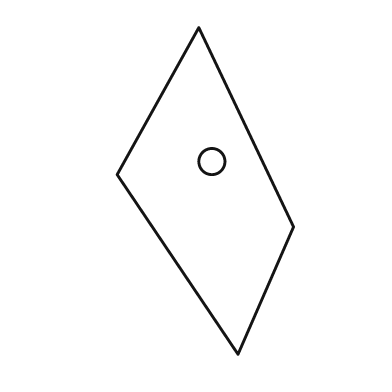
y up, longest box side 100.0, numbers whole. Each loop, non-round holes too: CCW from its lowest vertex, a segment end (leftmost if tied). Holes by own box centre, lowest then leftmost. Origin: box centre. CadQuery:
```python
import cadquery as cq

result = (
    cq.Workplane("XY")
    .moveTo(10.0, -50.0)
    .lineTo(27.0, -11.0)
    .lineTo(-2.0, 50.0)
    .lineTo(-27.0, 5.0)
    .close()
    .moveTo(2.0, 9.0)
    .circle(4.0)
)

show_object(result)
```